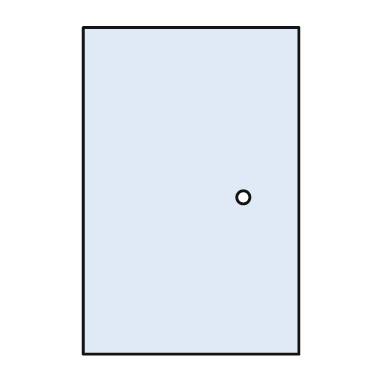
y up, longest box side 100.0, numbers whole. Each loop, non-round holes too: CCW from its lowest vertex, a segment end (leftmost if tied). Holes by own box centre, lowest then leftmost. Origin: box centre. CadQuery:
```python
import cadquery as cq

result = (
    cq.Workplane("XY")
    .moveTo(-33.0, -50.0)
    .lineTo(33.0, -50.0)
    .lineTo(33.0, 50.0)
    .lineTo(-33.0, 50.0)
    .close()
    .moveTo(16.0, -2.0)
    .circle(2.0)
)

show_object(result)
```